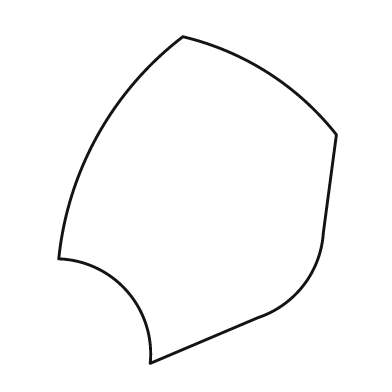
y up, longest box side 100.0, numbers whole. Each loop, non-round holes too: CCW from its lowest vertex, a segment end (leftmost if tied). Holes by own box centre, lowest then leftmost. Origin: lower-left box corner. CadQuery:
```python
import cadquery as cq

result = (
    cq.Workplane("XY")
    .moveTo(28.0, 0.0)
    .lineTo(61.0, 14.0)
    .threePointArc((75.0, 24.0), (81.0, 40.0))
    .lineTo(85.0, 70.0)
    .threePointArc((64.0, 89.0), (38.0, 100.0))
    .threePointArc((12.0, 70.0), (0.0, 32.0))
    .threePointArc((21.0, 22.0), (28.0, 0.0))
    .close()
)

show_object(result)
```